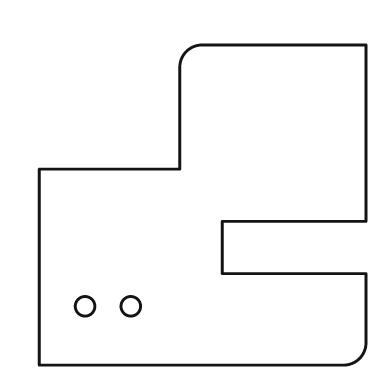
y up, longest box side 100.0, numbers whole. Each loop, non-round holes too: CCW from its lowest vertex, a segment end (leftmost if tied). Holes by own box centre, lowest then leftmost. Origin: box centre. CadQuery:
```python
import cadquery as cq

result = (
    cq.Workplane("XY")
    .moveTo(-50.0, -49.0)
    .lineTo(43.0, -49.0)
    .threePointArc((48.0, -47.0), (50.0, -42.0))
    .lineTo(50.0, -21.0)
    .lineTo(6.0, -21.0)
    .lineTo(6.0, -5.0)
    .lineTo(50.0, -5.0)
    .lineTo(50.0, 49.0)
    .lineTo(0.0, 49.0)
    .threePointArc((-5.0, 47.0), (-7.0, 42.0))
    .lineTo(-7.0, 11.0)
    .lineTo(-50.0, 11.0)
    .close()
    .moveTo(-36.0, -31.0)
    .circle(3.0)
    .moveTo(-22.0, -31.0)
    .circle(3.0)
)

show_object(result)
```